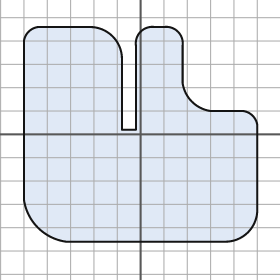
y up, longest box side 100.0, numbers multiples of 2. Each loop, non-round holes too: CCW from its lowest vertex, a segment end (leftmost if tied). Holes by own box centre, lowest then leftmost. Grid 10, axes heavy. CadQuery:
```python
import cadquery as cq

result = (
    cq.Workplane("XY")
    .moveTo(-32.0, -46.0)
    .lineTo(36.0, -46.0)
    .threePointArc((46.0, -42.0), (50.0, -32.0))
    .lineTo(50.0, 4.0)
    .threePointArc((48.0, 8.0), (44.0, 10.0))
    .lineTo(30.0, 10.0)
    .threePointArc((22.0, 14.0), (18.0, 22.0))
    .lineTo(18.0, 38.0)
    .threePointArc((16.0, 44.0), (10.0, 46.0))
    .lineTo(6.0, 46.0)
    .threePointArc((0.0, 44.0), (-2.0, 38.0))
    .lineTo(-2.0, 2.0)
    .lineTo(-8.0, 2.0)
    .lineTo(-8.0, 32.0)
    .threePointArc((-12.0, 42.0), (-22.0, 46.0))
    .lineTo(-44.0, 46.0)
    .threePointArc((-48.0, 44.0), (-50.0, 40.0))
    .lineTo(-50.0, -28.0)
    .threePointArc((-44.0, -40.0), (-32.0, -46.0))
    .close()
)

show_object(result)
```